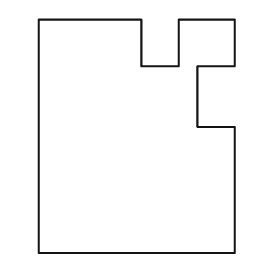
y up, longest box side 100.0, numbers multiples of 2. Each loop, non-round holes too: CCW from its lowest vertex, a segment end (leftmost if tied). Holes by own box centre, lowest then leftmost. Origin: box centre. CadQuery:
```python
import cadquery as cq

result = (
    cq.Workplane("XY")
    .moveTo(-42.0, -50.0)
    .lineTo(42.0, -50.0)
    .lineTo(42.0, 4.0)
    .lineTo(26.0, 4.0)
    .lineTo(26.0, 30.0)
    .lineTo(42.0, 30.0)
    .lineTo(42.0, 50.0)
    .lineTo(18.0, 50.0)
    .lineTo(18.0, 30.0)
    .lineTo(2.0, 30.0)
    .lineTo(2.0, 50.0)
    .lineTo(-42.0, 50.0)
    .close()
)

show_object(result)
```